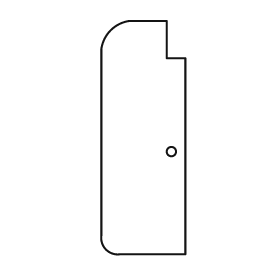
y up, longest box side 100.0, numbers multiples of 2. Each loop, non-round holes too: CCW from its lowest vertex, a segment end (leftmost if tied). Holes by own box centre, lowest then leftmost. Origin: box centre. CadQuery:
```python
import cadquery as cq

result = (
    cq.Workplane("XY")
    .moveTo(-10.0, -50.0)
    .lineTo(18.0, -50.0)
    .lineTo(18.0, 34.0)
    .lineTo(10.0, 34.0)
    .lineTo(10.0, 50.0)
    .lineTo(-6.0, 50.0)
    .threePointArc((-14.0, 46.0), (-18.0, 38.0))
    .lineTo(-18.0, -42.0)
    .threePointArc((-16.0, -48.0), (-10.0, -50.0))
    .close()
    .moveTo(12.0, -6.0)
    .circle(2.0)
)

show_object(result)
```